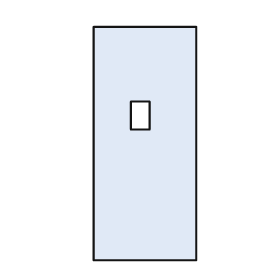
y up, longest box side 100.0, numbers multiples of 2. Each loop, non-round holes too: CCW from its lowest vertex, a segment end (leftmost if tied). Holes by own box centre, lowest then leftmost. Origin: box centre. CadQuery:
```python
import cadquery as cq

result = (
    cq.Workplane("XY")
    .moveTo(-22.0, -50.0)
    .lineTo(22.0, -50.0)
    .lineTo(22.0, 50.0)
    .lineTo(-22.0, 50.0)
    .close()
    .moveTo(-6.0, 6.0)
    .lineTo(2.0, 6.0)
    .lineTo(2.0, 18.0)
    .lineTo(-6.0, 18.0)
    .close()
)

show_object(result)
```